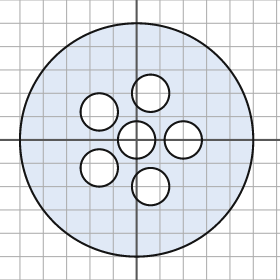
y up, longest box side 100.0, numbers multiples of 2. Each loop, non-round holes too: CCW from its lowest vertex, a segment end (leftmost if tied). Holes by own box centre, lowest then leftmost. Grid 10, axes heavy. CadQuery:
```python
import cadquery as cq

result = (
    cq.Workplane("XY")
    .moveTo(0.0, 0.0)
    .circle(50.0)
    .moveTo(6.0, -20.0)
    .circle(8.0)
    .moveTo(-16.0, -12.0)
    .circle(8.0)
    .moveTo(0.0, 0.0)
    .circle(8.0)
    .moveTo(20.0, 0.0)
    .circle(8.0)
    .moveTo(-16.0, 12.0)
    .circle(8.0)
    .moveTo(6.0, 20.0)
    .circle(8.0)
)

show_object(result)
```